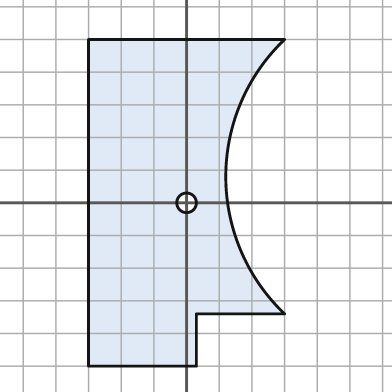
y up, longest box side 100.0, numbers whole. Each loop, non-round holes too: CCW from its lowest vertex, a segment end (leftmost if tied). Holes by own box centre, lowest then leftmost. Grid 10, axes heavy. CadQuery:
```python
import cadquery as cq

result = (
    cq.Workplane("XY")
    .moveTo(-30.0, -50.0)
    .lineTo(3.0, -50.0)
    .lineTo(3.0, -34.0)
    .lineTo(30.0, -34.0)
    .threePointArc((12.0, 8.0), (30.0, 50.0))
    .lineTo(-30.0, 50.0)
    .close()
    .moveTo(0.0, 0.0)
    .circle(3.0)
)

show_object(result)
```